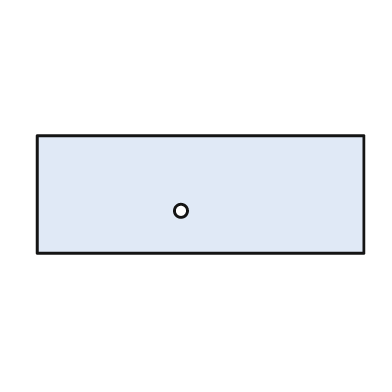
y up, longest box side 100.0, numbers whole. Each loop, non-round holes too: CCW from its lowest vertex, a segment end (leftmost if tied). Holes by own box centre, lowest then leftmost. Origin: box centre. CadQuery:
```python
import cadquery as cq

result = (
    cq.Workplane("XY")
    .moveTo(-50.0, -18.0)
    .lineTo(50.0, -18.0)
    .lineTo(50.0, 18.0)
    .lineTo(-50.0, 18.0)
    .close()
    .moveTo(-6.0, -5.0)
    .circle(2.0)
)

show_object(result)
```